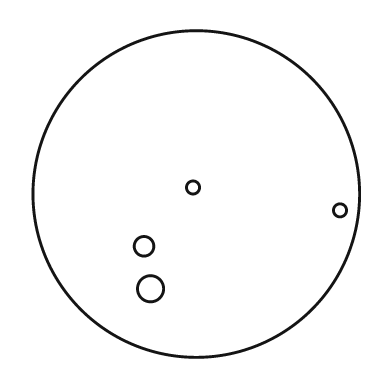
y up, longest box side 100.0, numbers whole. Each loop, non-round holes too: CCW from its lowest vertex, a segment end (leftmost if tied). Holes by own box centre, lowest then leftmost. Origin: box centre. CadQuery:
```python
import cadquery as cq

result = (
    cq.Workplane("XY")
    .moveTo(0.0, 0.0)
    .circle(50.0)
    .moveTo(-14.0, -29.0)
    .circle(4.0)
    .moveTo(-16.0, -16.0)
    .circle(3.0)
    .moveTo(44.0, -5.0)
    .circle(2.0)
    .moveTo(-1.0, 2.0)
    .circle(2.0)
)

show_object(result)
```